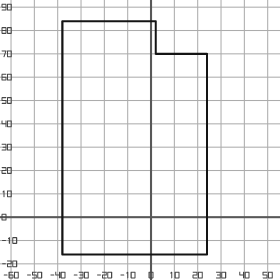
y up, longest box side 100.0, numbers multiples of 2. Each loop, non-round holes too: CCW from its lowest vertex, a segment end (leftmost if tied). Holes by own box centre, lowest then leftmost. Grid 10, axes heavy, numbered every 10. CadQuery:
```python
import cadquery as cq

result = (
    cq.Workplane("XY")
    .moveTo(-38.0, -16.0)
    .lineTo(24.0, -16.0)
    .lineTo(24.0, 70.0)
    .lineTo(2.0, 70.0)
    .lineTo(2.0, 84.0)
    .lineTo(-38.0, 84.0)
    .close()
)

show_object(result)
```